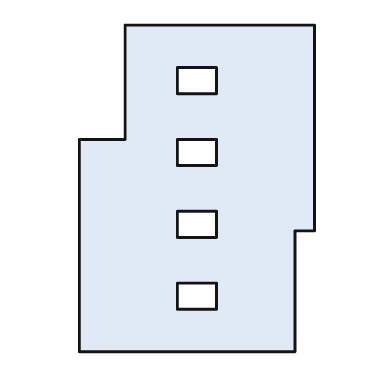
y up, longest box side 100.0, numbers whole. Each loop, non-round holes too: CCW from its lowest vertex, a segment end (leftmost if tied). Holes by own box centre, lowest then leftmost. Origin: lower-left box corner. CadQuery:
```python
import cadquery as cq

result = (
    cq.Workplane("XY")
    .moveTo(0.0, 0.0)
    .lineTo(66.0, 0.0)
    .lineTo(66.0, 37.0)
    .lineTo(72.0, 37.0)
    .lineTo(72.0, 100.0)
    .lineTo(14.0, 100.0)
    .lineTo(14.0, 65.0)
    .lineTo(0.0, 65.0)
    .close()
    .moveTo(30.0, 13.0)
    .lineTo(42.0, 13.0)
    .lineTo(42.0, 21.0)
    .lineTo(30.0, 21.0)
    .close()
    .moveTo(30.0, 35.0)
    .lineTo(42.0, 35.0)
    .lineTo(42.0, 43.0)
    .lineTo(30.0, 43.0)
    .close()
    .moveTo(30.0, 57.0)
    .lineTo(42.0, 57.0)
    .lineTo(42.0, 65.0)
    .lineTo(30.0, 65.0)
    .close()
    .moveTo(30.0, 79.0)
    .lineTo(42.0, 79.0)
    .lineTo(42.0, 87.0)
    .lineTo(30.0, 87.0)
    .close()
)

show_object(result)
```